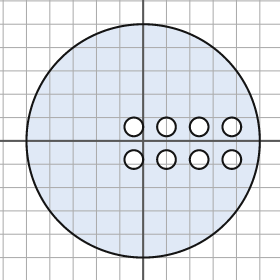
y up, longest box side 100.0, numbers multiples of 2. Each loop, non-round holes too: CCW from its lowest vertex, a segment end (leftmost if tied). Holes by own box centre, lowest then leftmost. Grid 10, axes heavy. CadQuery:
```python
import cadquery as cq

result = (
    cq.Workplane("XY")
    .moveTo(0.0, 0.0)
    .circle(50.0)
    .moveTo(-4.0, -8.0)
    .circle(4.0)
    .moveTo(10.0, -8.0)
    .circle(4.0)
    .moveTo(24.0, -8.0)
    .circle(4.0)
    .moveTo(38.0, -8.0)
    .circle(4.0)
    .moveTo(-4.0, 6.0)
    .circle(4.0)
    .moveTo(10.0, 6.0)
    .circle(4.0)
    .moveTo(24.0, 6.0)
    .circle(4.0)
    .moveTo(38.0, 6.0)
    .circle(4.0)
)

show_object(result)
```